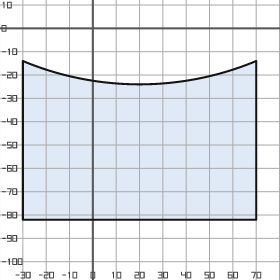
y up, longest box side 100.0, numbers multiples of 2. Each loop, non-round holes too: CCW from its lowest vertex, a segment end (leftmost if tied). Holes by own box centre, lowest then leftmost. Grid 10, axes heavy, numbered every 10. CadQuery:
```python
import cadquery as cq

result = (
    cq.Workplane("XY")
    .moveTo(-30.0, -82.0)
    .lineTo(70.0, -82.0)
    .lineTo(70.0, -14.0)
    .threePointArc((20.0, -24.0), (-30.0, -14.0))
    .close()
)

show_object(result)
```